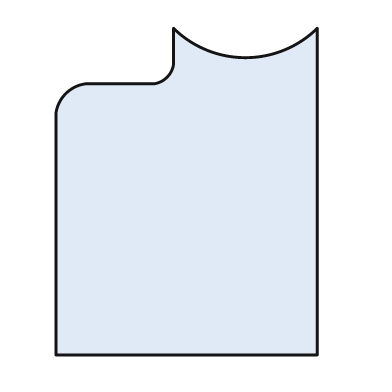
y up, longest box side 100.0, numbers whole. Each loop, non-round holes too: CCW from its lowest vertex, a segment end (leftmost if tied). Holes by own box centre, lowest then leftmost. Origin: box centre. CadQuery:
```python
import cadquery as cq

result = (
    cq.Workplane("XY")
    .moveTo(-40.0, -50.0)
    .lineTo(40.0, -50.0)
    .lineTo(40.0, 50.0)
    .threePointArc((18.0, 41.0), (-4.0, 50.0))
    .lineTo(-4.0, 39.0)
    .threePointArc((-6.0, 35.0), (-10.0, 33.0))
    .lineTo(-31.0, 33.0)
    .threePointArc((-37.0, 30.0), (-40.0, 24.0))
    .close()
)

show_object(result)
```